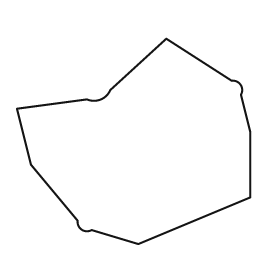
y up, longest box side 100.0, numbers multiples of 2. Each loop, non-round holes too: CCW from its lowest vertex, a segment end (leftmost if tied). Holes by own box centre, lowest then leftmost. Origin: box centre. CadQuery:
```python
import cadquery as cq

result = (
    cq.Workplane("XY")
    .moveTo(2.0, -44.0)
    .lineTo(50.0, -24.0)
    .lineTo(50.0, 4.0)
    .lineTo(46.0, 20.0)
    .threePointArc((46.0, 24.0), (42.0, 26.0))
    .lineTo(14.0, 44.0)
    .lineTo(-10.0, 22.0)
    .threePointArc((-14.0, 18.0), (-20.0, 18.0))
    .lineTo(-50.0, 14.0)
    .lineTo(-44.0, -10.0)
    .lineTo(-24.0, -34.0)
    .threePointArc((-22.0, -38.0), (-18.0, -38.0))
    .close()
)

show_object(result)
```